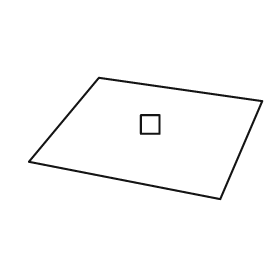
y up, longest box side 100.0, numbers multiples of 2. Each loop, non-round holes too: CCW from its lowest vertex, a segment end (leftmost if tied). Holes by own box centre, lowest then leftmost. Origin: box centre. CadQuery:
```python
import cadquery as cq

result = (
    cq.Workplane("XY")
    .moveTo(32.0, -26.0)
    .lineTo(50.0, 16.0)
    .lineTo(-20.0, 26.0)
    .lineTo(-50.0, -10.0)
    .close()
    .moveTo(-2.0, 2.0)
    .lineTo(6.0, 2.0)
    .lineTo(6.0, 10.0)
    .lineTo(-2.0, 10.0)
    .close()
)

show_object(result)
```